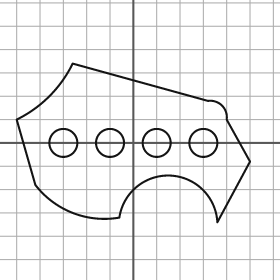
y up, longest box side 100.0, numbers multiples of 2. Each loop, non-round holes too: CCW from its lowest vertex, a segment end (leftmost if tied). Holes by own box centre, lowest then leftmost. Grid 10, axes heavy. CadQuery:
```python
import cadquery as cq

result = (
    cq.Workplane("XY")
    .moveTo(36.0, -34.0)
    .lineTo(50.0, -8.0)
    .lineTo(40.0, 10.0)
    .threePointArc((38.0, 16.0), (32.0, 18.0))
    .lineTo(-26.0, 34.0)
    .threePointArc((-36.0, 20.0), (-50.0, 10.0))
    .lineTo(-42.0, -18.0)
    .threePointArc((-26.0, -30.0), (-6.0, -32.0))
    .threePointArc((16.0, -14.0), (36.0, -34.0))
    .close()
    .moveTo(-30.0, 0.0)
    .circle(6.0)
    .moveTo(-10.0, 0.0)
    .circle(6.0)
    .moveTo(10.0, 0.0)
    .circle(6.0)
    .moveTo(30.0, 0.0)
    .circle(6.0)
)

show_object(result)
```